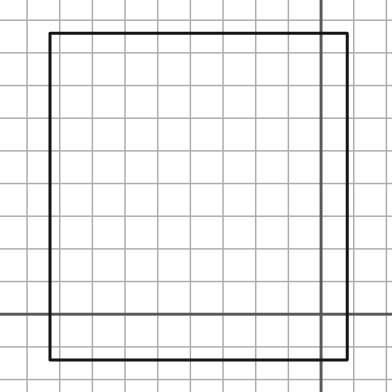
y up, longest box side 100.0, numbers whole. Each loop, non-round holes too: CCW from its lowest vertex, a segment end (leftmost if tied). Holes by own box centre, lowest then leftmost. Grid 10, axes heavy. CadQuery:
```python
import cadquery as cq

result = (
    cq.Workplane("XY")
    .moveTo(-83.0, -14.0)
    .lineTo(8.0, -14.0)
    .lineTo(8.0, 86.0)
    .lineTo(-83.0, 86.0)
    .close()
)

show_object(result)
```